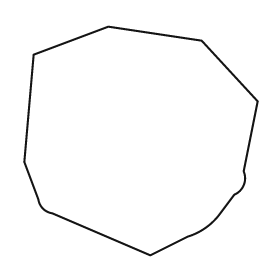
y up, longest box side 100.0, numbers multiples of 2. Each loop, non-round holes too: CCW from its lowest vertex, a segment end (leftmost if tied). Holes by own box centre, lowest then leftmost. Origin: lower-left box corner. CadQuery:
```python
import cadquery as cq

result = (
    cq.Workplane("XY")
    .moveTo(54.0, 0.0)
    .lineTo(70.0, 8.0)
    .threePointArc((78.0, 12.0), (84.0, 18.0))
    .lineTo(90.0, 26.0)
    .threePointArc((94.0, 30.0), (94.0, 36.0))
    .lineTo(100.0, 66.0)
    .lineTo(76.0, 92.0)
    .lineTo(36.0, 98.0)
    .lineTo(4.0, 86.0)
    .lineTo(0.0, 40.0)
    .lineTo(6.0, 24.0)
    .threePointArc((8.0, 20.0), (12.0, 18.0))
    .close()
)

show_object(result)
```